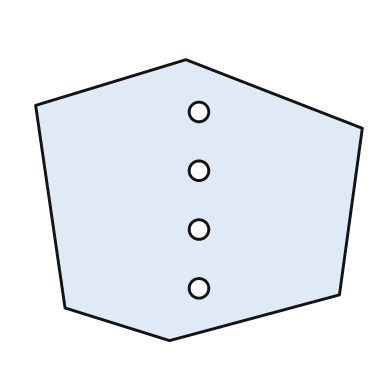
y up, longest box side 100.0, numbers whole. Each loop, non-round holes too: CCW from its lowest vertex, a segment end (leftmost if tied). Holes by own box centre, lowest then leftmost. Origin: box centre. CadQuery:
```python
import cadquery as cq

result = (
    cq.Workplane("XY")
    .moveTo(-9.0, -43.0)
    .lineTo(43.0, -29.0)
    .lineTo(50.0, 22.0)
    .lineTo(-4.0, 43.0)
    .lineTo(-50.0, 29.0)
    .lineTo(-41.0, -33.0)
    .close()
    .moveTo(0.0, -27.0)
    .circle(3.0)
    .moveTo(0.0, -9.0)
    .circle(3.0)
    .moveTo(0.0, 9.0)
    .circle(3.0)
    .moveTo(0.0, 27.0)
    .circle(3.0)
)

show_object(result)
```